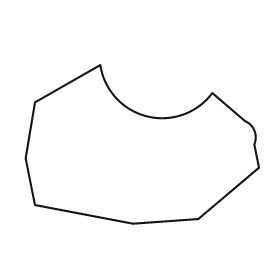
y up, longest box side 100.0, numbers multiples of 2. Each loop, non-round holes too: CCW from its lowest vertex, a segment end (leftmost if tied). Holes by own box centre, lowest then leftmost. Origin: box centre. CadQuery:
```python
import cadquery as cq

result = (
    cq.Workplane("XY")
    .moveTo(-4.0, -34.0)
    .lineTo(24.0, -32.0)
    .lineTo(50.0, -10.0)
    .lineTo(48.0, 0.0)
    .threePointArc((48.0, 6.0), (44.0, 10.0))
    .lineTo(30.0, 22.0)
    .threePointArc((2.0, 12.0), (-18.0, 34.0))
    .lineTo(-46.0, 18.0)
    .lineTo(-50.0, -6.0)
    .lineTo(-46.0, -26.0)
    .close()
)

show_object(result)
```